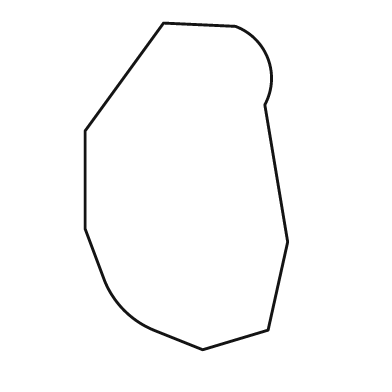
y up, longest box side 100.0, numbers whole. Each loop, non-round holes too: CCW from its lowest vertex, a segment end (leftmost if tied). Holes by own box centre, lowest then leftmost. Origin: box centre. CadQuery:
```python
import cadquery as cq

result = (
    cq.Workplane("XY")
    .moveTo(5.0, -50.0)
    .lineTo(25.0, -44.0)
    .lineTo(31.0, -17.0)
    .lineTo(24.0, 25.0)
    .threePointArc((25.0, 39.0), (15.0, 49.0))
    .lineTo(-7.0, 50.0)
    .lineTo(-31.0, 17.0)
    .lineTo(-31.0, -13.0)
    .lineTo(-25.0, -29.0)
    .threePointArc((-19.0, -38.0), (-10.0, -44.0))
    .close()
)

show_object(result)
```